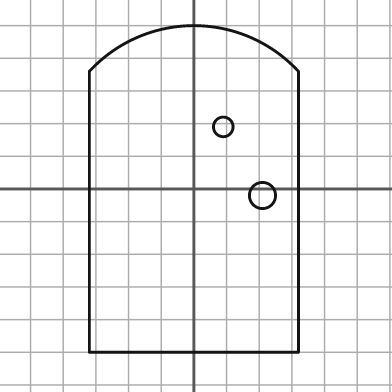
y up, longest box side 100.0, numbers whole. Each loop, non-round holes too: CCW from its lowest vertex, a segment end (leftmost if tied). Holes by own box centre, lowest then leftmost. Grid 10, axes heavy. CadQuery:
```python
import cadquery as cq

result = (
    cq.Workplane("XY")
    .moveTo(-32.0, -50.0)
    .lineTo(32.0, -50.0)
    .lineTo(32.0, 36.0)
    .threePointArc((0.0, 50.0), (-32.0, 36.0))
    .close()
    .moveTo(21.0, -2.0)
    .circle(4.0)
    .moveTo(9.0, 19.0)
    .circle(3.0)
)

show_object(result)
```